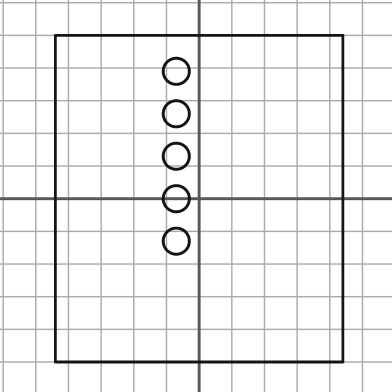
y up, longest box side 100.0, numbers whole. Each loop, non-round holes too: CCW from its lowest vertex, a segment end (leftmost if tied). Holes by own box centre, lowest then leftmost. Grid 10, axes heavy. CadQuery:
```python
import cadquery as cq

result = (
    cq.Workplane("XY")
    .moveTo(-44.0, -50.0)
    .lineTo(44.0, -50.0)
    .lineTo(44.0, 50.0)
    .lineTo(-44.0, 50.0)
    .close()
    .moveTo(-7.0, -13.0)
    .circle(4.0)
    .moveTo(-7.0, 0.0)
    .circle(4.0)
    .moveTo(-7.0, 13.0)
    .circle(4.0)
    .moveTo(-7.0, 26.0)
    .circle(4.0)
    .moveTo(-7.0, 39.0)
    .circle(4.0)
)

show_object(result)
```